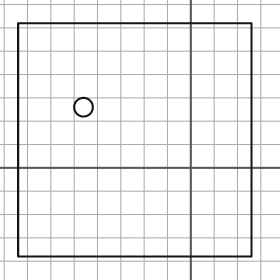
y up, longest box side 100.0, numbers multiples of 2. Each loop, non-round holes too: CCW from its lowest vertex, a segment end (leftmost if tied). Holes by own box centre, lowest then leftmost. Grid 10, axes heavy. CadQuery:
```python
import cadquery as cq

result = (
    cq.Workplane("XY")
    .moveTo(-74.0, -38.0)
    .lineTo(26.0, -38.0)
    .lineTo(26.0, 62.0)
    .lineTo(-74.0, 62.0)
    .close()
    .moveTo(-46.0, 26.0)
    .circle(4.0)
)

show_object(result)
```